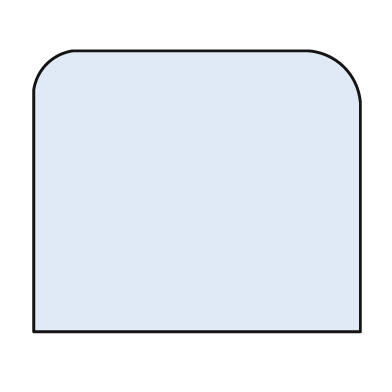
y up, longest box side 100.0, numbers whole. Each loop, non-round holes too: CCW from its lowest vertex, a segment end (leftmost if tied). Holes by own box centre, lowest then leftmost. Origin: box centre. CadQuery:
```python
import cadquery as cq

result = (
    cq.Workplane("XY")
    .moveTo(-50.0, -43.0)
    .lineTo(50.0, -43.0)
    .lineTo(50.0, 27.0)
    .threePointArc((45.0, 38.0), (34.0, 43.0))
    .lineTo(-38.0, 43.0)
    .threePointArc((-46.0, 39.0), (-50.0, 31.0))
    .close()
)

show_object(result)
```